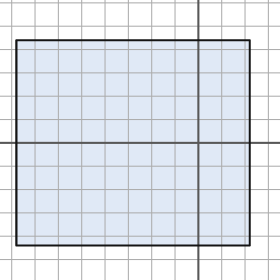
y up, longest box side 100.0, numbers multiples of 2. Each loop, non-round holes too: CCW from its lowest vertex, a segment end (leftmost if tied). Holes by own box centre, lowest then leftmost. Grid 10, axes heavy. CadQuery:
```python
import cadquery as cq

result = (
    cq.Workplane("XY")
    .moveTo(-78.0, -44.0)
    .lineTo(22.0, -44.0)
    .lineTo(22.0, 44.0)
    .lineTo(-78.0, 44.0)
    .close()
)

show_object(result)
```